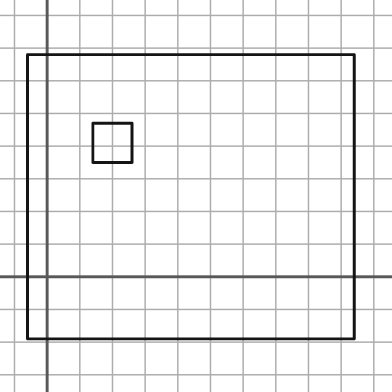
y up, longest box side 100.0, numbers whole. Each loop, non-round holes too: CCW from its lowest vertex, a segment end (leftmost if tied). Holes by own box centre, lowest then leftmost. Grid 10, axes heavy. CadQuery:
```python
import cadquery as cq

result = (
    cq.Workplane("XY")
    .moveTo(-6.0, -19.0)
    .lineTo(94.0, -19.0)
    .lineTo(94.0, 68.0)
    .lineTo(-6.0, 68.0)
    .close()
    .moveTo(14.0, 35.0)
    .lineTo(26.0, 35.0)
    .lineTo(26.0, 47.0)
    .lineTo(14.0, 47.0)
    .close()
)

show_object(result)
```